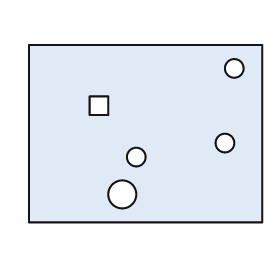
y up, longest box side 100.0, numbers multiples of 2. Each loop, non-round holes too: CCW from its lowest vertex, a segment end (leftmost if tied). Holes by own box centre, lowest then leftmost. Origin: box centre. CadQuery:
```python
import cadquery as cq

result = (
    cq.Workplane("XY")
    .moveTo(-50.0, -38.0)
    .lineTo(50.0, -38.0)
    .lineTo(50.0, 38.0)
    .lineTo(-50.0, 38.0)
    .close()
    .moveTo(-10.0, -26.0)
    .circle(6.0)
    .moveTo(-4.0, -10.0)
    .circle(4.0)
    .moveTo(34.0, -4.0)
    .circle(4.0)
    .moveTo(-24.0, 8.0)
    .lineTo(-16.0, 8.0)
    .lineTo(-16.0, 16.0)
    .lineTo(-24.0, 16.0)
    .close()
    .moveTo(38.0, 28.0)
    .circle(4.0)
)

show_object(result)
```